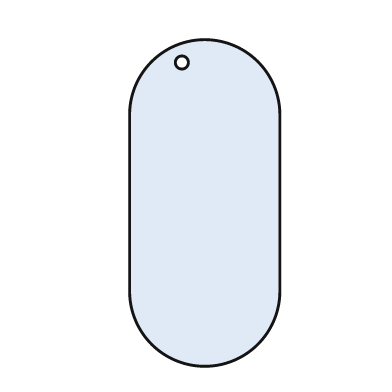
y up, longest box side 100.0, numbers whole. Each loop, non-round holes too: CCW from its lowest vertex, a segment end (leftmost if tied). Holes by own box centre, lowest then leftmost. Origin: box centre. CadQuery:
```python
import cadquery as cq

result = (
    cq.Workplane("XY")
    .moveTo(-23.0, -27.0)
    .threePointArc((0.0, -50.0), (23.0, -27.0))
    .lineTo(23.0, 27.0)
    .threePointArc((0.0, 50.0), (-23.0, 27.0))
    .close()
    .moveTo(-7.0, 43.0)
    .circle(2.0)
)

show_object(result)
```